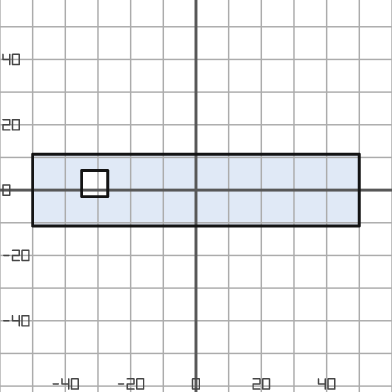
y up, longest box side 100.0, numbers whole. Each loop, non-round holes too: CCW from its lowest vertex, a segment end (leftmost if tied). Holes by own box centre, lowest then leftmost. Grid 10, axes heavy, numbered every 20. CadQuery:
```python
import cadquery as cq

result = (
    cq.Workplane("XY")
    .moveTo(-50.0, -11.0)
    .lineTo(50.0, -11.0)
    .lineTo(50.0, 11.0)
    .lineTo(-50.0, 11.0)
    .close()
    .moveTo(-35.0, -2.0)
    .lineTo(-27.0, -2.0)
    .lineTo(-27.0, 6.0)
    .lineTo(-35.0, 6.0)
    .close()
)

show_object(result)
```